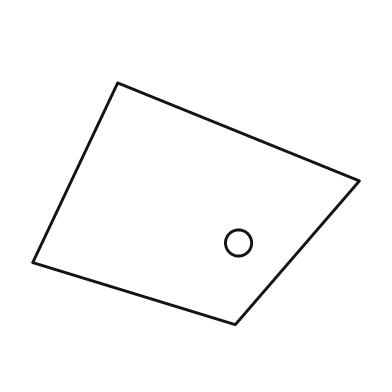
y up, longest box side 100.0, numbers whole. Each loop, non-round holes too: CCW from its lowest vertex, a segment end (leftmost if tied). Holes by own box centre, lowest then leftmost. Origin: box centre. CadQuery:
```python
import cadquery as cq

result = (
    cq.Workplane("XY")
    .moveTo(12.0, -37.0)
    .lineTo(50.0, 7.0)
    .lineTo(-24.0, 37.0)
    .lineTo(-50.0, -18.0)
    .close()
    .moveTo(13.0, -12.0)
    .circle(4.0)
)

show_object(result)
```